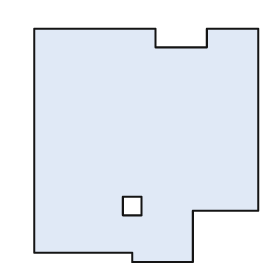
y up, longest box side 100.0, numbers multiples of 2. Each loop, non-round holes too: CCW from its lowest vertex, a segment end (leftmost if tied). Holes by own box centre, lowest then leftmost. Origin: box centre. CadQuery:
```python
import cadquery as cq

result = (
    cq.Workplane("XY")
    .moveTo(-6.0, -50.0)
    .lineTo(20.0, -50.0)
    .lineTo(20.0, -28.0)
    .lineTo(48.0, -28.0)
    .lineTo(48.0, 50.0)
    .lineTo(26.0, 50.0)
    .lineTo(26.0, 42.0)
    .lineTo(4.0, 42.0)
    .lineTo(4.0, 50.0)
    .lineTo(-48.0, 50.0)
    .lineTo(-48.0, -46.0)
    .lineTo(-6.0, -46.0)
    .close()
    .moveTo(-10.0, -30.0)
    .lineTo(-2.0, -30.0)
    .lineTo(-2.0, -22.0)
    .lineTo(-10.0, -22.0)
    .close()
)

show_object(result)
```